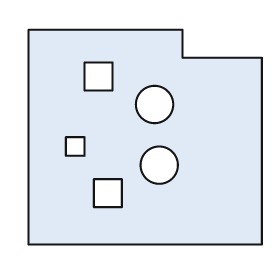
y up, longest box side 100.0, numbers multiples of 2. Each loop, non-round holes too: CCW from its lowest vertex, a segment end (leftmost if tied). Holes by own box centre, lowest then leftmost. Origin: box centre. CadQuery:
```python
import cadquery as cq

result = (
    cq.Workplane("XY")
    .moveTo(-50.0, -46.0)
    .lineTo(50.0, -46.0)
    .lineTo(50.0, 34.0)
    .lineTo(16.0, 34.0)
    .lineTo(16.0, 46.0)
    .lineTo(-50.0, 46.0)
    .close()
    .moveTo(-22.0, -30.0)
    .lineTo(-10.0, -30.0)
    .lineTo(-10.0, -18.0)
    .lineTo(-22.0, -18.0)
    .close()
    .moveTo(6.0, -12.0)
    .circle(8.0)
    .moveTo(-34.0, -8.0)
    .lineTo(-26.0, -8.0)
    .lineTo(-26.0, 0.0)
    .lineTo(-34.0, 0.0)
    .close()
    .moveTo(4.0, 14.0)
    .circle(8.0)
    .moveTo(-26.0, 20.0)
    .lineTo(-14.0, 20.0)
    .lineTo(-14.0, 32.0)
    .lineTo(-26.0, 32.0)
    .close()
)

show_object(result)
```